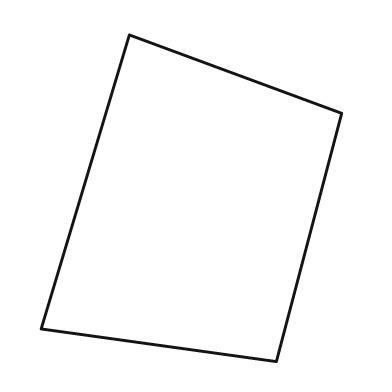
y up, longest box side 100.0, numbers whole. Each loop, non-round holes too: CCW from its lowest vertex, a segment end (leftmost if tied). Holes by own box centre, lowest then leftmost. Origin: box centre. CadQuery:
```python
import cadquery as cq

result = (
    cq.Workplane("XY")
    .moveTo(26.0, -50.0)
    .lineTo(46.0, 26.0)
    .lineTo(-19.0, 50.0)
    .lineTo(-46.0, -40.0)
    .close()
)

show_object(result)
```